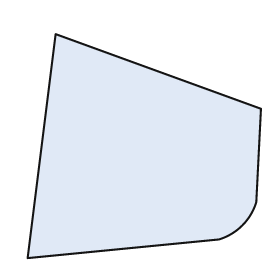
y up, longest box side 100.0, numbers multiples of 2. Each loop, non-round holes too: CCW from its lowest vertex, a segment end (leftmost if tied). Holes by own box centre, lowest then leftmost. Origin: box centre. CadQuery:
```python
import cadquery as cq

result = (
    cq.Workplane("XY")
    .moveTo(-50.0, -48.0)
    .lineTo(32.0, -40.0)
    .threePointArc((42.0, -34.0), (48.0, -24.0))
    .lineTo(50.0, 16.0)
    .lineTo(-38.0, 48.0)
    .close()
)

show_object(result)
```